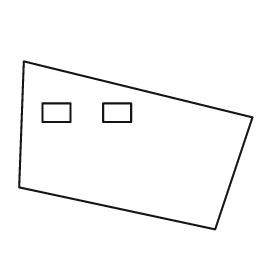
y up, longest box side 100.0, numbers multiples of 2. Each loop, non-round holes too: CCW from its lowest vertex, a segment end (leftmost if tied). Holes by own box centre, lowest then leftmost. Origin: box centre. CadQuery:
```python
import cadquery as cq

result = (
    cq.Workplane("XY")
    .moveTo(34.0, -36.0)
    .lineTo(50.0, 12.0)
    .lineTo(-48.0, 36.0)
    .lineTo(-50.0, -18.0)
    .close()
    .moveTo(-40.0, 10.0)
    .lineTo(-28.0, 10.0)
    .lineTo(-28.0, 18.0)
    .lineTo(-40.0, 18.0)
    .close()
    .moveTo(-14.0, 10.0)
    .lineTo(-2.0, 10.0)
    .lineTo(-2.0, 18.0)
    .lineTo(-14.0, 18.0)
    .close()
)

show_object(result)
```